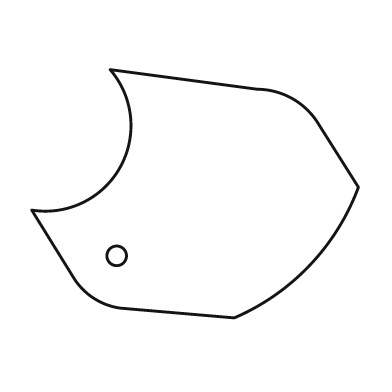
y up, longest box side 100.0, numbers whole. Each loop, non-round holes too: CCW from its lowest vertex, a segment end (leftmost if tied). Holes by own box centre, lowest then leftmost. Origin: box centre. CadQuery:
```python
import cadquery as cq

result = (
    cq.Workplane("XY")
    .moveTo(12.0, -38.0)
    .threePointArc((35.0, -22.0), (50.0, 2.0))
    .lineTo(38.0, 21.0)
    .threePointArc((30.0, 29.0), (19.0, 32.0))
    .lineTo(-26.0, 38.0)
    .threePointArc((-23.0, 8.0), (-50.0, -5.0))
    .lineTo(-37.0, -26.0)
    .threePointArc((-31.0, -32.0), (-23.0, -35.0))
    .close()
    .moveTo(-24.0, -19.0)
    .circle(3.0)
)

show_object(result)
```